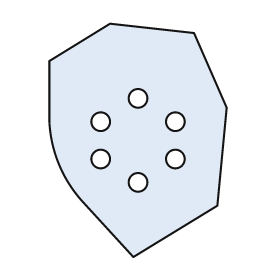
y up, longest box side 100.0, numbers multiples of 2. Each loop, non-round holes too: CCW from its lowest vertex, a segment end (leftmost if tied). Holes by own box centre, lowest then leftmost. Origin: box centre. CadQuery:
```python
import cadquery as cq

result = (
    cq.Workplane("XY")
    .moveTo(-2.0, -50.0)
    .lineTo(34.0, -28.0)
    .lineTo(38.0, 14.0)
    .lineTo(24.0, 46.0)
    .lineTo(-12.0, 50.0)
    .lineTo(-38.0, 34.0)
    .lineTo(-38.0, 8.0)
    .threePointArc((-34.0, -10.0), (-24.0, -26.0))
    .close()
    .moveTo(0.0, -18.0)
    .circle(4.0)
    .moveTo(-16.0, -8.0)
    .circle(4.0)
    .moveTo(16.0, -8.0)
    .circle(4.0)
    .moveTo(-16.0, 8.0)
    .circle(4.0)
    .moveTo(16.0, 8.0)
    .circle(4.0)
    .moveTo(0.0, 18.0)
    .circle(4.0)
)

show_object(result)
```